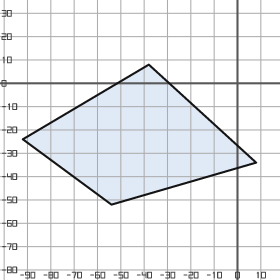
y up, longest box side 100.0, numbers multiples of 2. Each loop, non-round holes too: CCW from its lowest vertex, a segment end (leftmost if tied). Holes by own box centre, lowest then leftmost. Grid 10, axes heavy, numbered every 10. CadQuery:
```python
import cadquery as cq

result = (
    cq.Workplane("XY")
    .moveTo(-54.0, -52.0)
    .lineTo(8.0, -34.0)
    .lineTo(-38.0, 8.0)
    .lineTo(-92.0, -24.0)
    .close()
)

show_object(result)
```